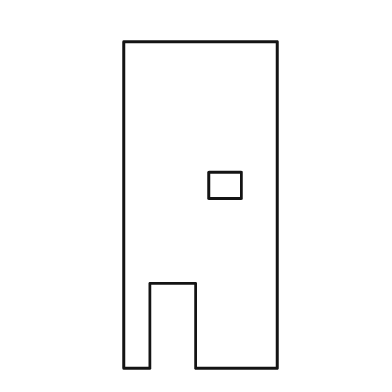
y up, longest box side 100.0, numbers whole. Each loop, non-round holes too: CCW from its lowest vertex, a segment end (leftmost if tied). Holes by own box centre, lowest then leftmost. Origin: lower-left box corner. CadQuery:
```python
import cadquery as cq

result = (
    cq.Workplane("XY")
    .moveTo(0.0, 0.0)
    .lineTo(8.0, 0.0)
    .lineTo(8.0, 26.0)
    .lineTo(22.0, 26.0)
    .lineTo(22.0, 0.0)
    .lineTo(47.0, 0.0)
    .lineTo(47.0, 100.0)
    .lineTo(0.0, 100.0)
    .close()
    .moveTo(26.0, 52.0)
    .lineTo(36.0, 52.0)
    .lineTo(36.0, 60.0)
    .lineTo(26.0, 60.0)
    .close()
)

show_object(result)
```